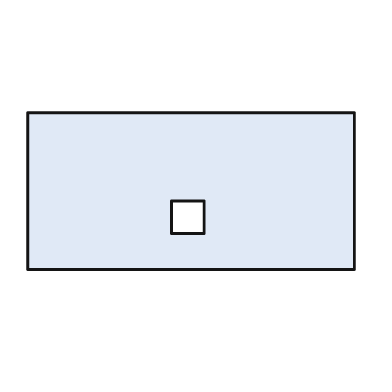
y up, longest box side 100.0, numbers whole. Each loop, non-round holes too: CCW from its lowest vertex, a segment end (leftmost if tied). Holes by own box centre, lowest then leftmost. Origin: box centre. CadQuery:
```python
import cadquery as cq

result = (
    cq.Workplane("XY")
    .moveTo(-50.0, -24.0)
    .lineTo(50.0, -24.0)
    .lineTo(50.0, 24.0)
    .lineTo(-50.0, 24.0)
    .close()
    .moveTo(-6.0, -13.0)
    .lineTo(4.0, -13.0)
    .lineTo(4.0, -3.0)
    .lineTo(-6.0, -3.0)
    .close()
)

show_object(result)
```